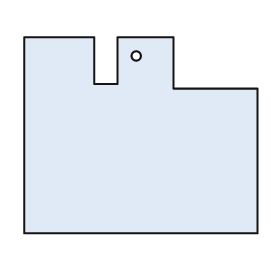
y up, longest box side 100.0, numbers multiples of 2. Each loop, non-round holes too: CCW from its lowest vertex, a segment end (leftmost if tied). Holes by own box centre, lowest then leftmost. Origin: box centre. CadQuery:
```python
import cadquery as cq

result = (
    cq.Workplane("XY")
    .moveTo(-50.0, -42.0)
    .lineTo(50.0, -42.0)
    .lineTo(50.0, 20.0)
    .lineTo(14.0, 20.0)
    .lineTo(14.0, 42.0)
    .lineTo(-10.0, 42.0)
    .lineTo(-10.0, 22.0)
    .lineTo(-20.0, 22.0)
    .lineTo(-20.0, 42.0)
    .lineTo(-50.0, 42.0)
    .close()
    .moveTo(-2.0, 34.0)
    .circle(2.0)
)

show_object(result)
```